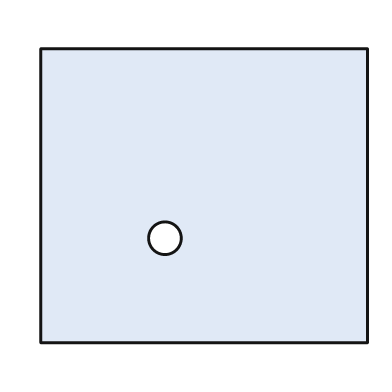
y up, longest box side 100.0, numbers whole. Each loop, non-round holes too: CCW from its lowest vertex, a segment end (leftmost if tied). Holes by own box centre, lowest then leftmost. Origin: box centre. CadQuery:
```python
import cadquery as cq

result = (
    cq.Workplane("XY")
    .moveTo(-50.0, -45.0)
    .lineTo(50.0, -45.0)
    .lineTo(50.0, 45.0)
    .lineTo(-50.0, 45.0)
    .close()
    .moveTo(-12.0, -13.0)
    .circle(5.0)
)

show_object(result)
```